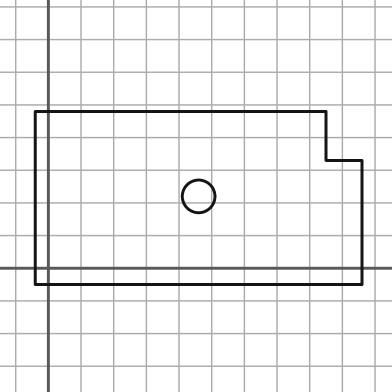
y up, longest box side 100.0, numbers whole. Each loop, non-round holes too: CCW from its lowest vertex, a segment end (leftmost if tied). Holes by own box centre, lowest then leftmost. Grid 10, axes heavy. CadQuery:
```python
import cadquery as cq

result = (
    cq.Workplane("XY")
    .moveTo(-4.0, -5.0)
    .lineTo(96.0, -5.0)
    .lineTo(96.0, 33.0)
    .lineTo(85.0, 33.0)
    .lineTo(85.0, 48.0)
    .lineTo(-4.0, 48.0)
    .close()
    .moveTo(46.0, 22.0)
    .circle(5.0)
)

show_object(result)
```